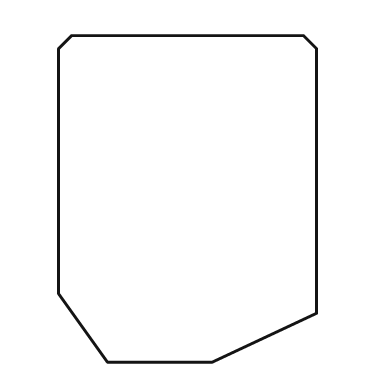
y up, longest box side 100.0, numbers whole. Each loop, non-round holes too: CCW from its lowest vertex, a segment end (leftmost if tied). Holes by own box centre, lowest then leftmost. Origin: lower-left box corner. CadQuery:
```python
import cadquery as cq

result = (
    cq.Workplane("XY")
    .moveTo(15.0, 0.0)
    .lineTo(47.0, 0.0)
    .lineTo(79.0, 15.0)
    .lineTo(79.0, 96.0)
    .lineTo(75.0, 100.0)
    .lineTo(4.0, 100.0)
    .lineTo(0.0, 96.0)
    .lineTo(0.0, 21.0)
    .close()
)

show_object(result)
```